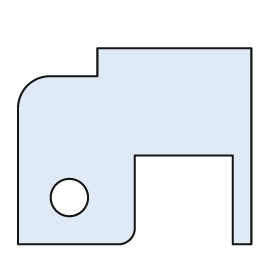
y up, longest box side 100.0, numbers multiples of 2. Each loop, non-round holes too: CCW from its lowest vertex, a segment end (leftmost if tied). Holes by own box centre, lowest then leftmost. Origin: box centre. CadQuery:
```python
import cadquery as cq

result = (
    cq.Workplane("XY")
    .moveTo(-50.0, -42.0)
    .lineTo(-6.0, -42.0)
    .threePointArc((-2.0, -40.0), (0.0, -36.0))
    .lineTo(0.0, -4.0)
    .lineTo(42.0, -4.0)
    .lineTo(42.0, -42.0)
    .lineTo(50.0, -42.0)
    .lineTo(50.0, 42.0)
    .lineTo(-16.0, 42.0)
    .lineTo(-16.0, 30.0)
    .lineTo(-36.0, 30.0)
    .threePointArc((-46.0, 26.0), (-50.0, 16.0))
    .close()
    .moveTo(-28.0, -22.0)
    .circle(8.0)
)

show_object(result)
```